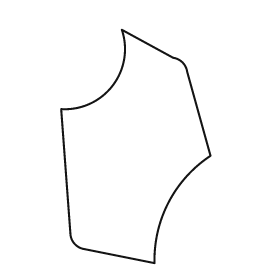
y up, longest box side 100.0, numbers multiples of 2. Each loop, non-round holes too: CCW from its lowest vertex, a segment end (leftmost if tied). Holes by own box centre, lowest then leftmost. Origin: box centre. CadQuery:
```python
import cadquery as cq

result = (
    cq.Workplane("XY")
    .moveTo(8.0, -50.0)
    .threePointArc((14.0, -24.0), (32.0, -4.0))
    .lineTo(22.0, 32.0)
    .threePointArc((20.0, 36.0), (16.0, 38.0))
    .lineTo(-6.0, 50.0)
    .threePointArc((-10.0, 26.0), (-32.0, 16.0))
    .lineTo(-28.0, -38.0)
    .threePointArc((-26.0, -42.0), (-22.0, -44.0))
    .close()
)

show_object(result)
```